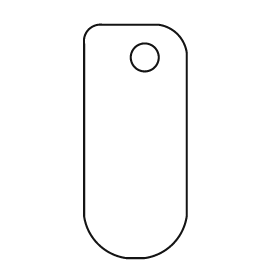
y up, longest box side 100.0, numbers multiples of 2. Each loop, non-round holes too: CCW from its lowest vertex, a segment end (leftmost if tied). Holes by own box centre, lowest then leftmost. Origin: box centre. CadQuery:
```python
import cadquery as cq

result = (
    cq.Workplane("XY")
    .moveTo(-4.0, -50.0)
    .lineTo(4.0, -50.0)
    .threePointArc((16.0, -44.0), (22.0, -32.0))
    .lineTo(22.0, 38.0)
    .threePointArc((18.0, 46.0), (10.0, 50.0))
    .lineTo(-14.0, 50.0)
    .threePointArc((-20.0, 48.0), (-22.0, 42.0))
    .lineTo(-22.0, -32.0)
    .threePointArc((-16.0, -44.0), (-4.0, -50.0))
    .close()
    .moveTo(4.0, 36.0)
    .circle(6.0)
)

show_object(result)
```